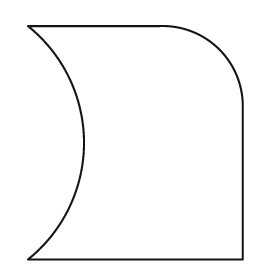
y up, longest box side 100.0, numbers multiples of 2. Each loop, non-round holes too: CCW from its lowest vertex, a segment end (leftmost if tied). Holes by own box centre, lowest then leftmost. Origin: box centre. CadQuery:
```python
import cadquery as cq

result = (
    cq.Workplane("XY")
    .moveTo(-46.0, -50.0)
    .lineTo(46.0, -50.0)
    .lineTo(46.0, 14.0)
    .threePointArc((36.0, 40.0), (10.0, 50.0))
    .lineTo(-46.0, 50.0)
    .threePointArc((-22.0, 0.0), (-46.0, -50.0))
    .close()
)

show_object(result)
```